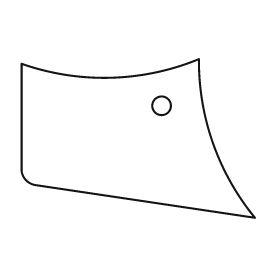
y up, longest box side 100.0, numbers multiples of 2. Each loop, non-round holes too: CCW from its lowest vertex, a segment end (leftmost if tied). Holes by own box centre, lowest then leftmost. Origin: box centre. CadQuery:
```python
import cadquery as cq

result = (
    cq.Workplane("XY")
    .moveTo(50.0, -34.0)
    .threePointArc((32.0, -2.0), (26.0, 34.0))
    .threePointArc((-12.0, 26.0), (-50.0, 32.0))
    .lineTo(-50.0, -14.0)
    .threePointArc((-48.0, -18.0), (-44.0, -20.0))
    .close()
    .moveTo(10.0, 14.0)
    .circle(4.0)
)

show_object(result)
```